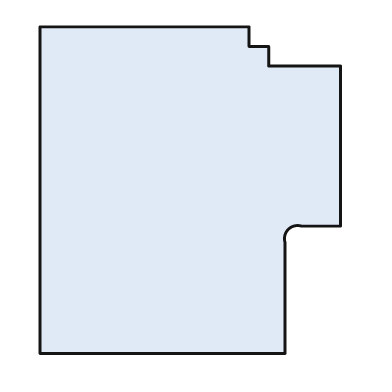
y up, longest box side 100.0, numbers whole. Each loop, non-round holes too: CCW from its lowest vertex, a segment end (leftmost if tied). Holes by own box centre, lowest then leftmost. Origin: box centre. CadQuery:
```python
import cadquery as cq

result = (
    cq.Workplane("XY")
    .moveTo(-46.0, -50.0)
    .lineTo(29.0, -50.0)
    .lineTo(29.0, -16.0)
    .threePointArc((30.0, -12.0), (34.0, -11.0))
    .lineTo(46.0, -11.0)
    .lineTo(46.0, 38.0)
    .lineTo(24.0, 38.0)
    .lineTo(24.0, 44.0)
    .lineTo(18.0, 44.0)
    .lineTo(18.0, 50.0)
    .lineTo(-46.0, 50.0)
    .close()
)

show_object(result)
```